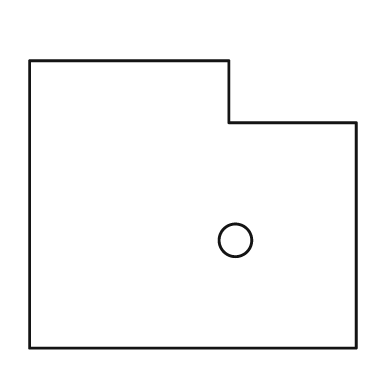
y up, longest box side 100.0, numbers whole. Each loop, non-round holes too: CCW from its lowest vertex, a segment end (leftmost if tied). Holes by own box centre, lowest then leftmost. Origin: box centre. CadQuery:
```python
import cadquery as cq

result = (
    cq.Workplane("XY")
    .moveTo(-50.0, -44.0)
    .lineTo(50.0, -44.0)
    .lineTo(50.0, 25.0)
    .lineTo(11.0, 25.0)
    .lineTo(11.0, 44.0)
    .lineTo(-50.0, 44.0)
    .close()
    .moveTo(13.0, -11.0)
    .circle(5.0)
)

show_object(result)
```